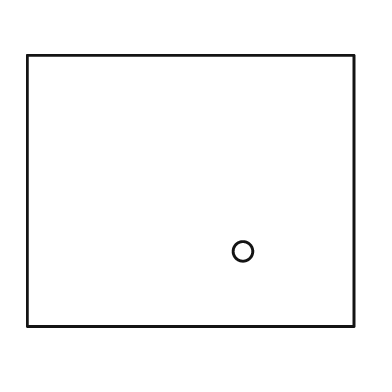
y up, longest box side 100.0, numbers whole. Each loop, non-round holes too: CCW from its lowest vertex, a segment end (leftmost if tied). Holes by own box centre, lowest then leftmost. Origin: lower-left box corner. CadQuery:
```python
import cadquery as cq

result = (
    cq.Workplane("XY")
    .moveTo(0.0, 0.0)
    .lineTo(100.0, 0.0)
    .lineTo(100.0, 83.0)
    .lineTo(0.0, 83.0)
    .close()
    .moveTo(66.0, 23.0)
    .circle(3.0)
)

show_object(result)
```